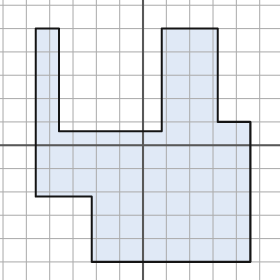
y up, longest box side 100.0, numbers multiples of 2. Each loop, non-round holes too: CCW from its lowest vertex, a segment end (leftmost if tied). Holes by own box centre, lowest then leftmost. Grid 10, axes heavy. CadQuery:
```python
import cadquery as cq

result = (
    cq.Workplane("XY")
    .moveTo(-22.0, -50.0)
    .lineTo(46.0, -50.0)
    .lineTo(46.0, 10.0)
    .lineTo(32.0, 10.0)
    .lineTo(32.0, 50.0)
    .lineTo(8.0, 50.0)
    .lineTo(8.0, 6.0)
    .lineTo(-36.0, 6.0)
    .lineTo(-36.0, 50.0)
    .lineTo(-46.0, 50.0)
    .lineTo(-46.0, -22.0)
    .lineTo(-22.0, -22.0)
    .close()
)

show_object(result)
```